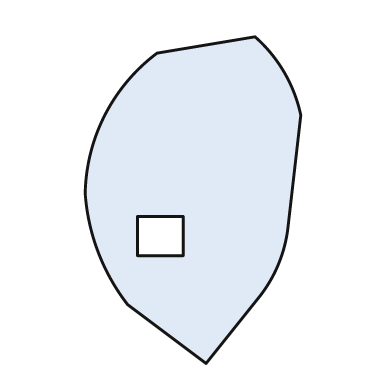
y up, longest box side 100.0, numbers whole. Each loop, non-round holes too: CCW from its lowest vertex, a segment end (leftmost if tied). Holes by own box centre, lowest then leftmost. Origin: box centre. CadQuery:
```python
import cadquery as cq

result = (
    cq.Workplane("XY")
    .moveTo(4.0, -50.0)
    .lineTo(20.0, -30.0)
    .threePointArc((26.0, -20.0), (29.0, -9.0))
    .lineTo(33.0, 26.0)
    .threePointArc((28.0, 39.0), (19.0, 50.0))
    .lineTo(-11.0, 45.0)
    .threePointArc((-27.0, 26.0), (-33.0, 2.0))
    .threePointArc((-29.0, -16.0), (-20.0, -32.0))
    .close()
    .moveTo(-17.0, -17.0)
    .lineTo(-3.0, -17.0)
    .lineTo(-3.0, -5.0)
    .lineTo(-17.0, -5.0)
    .close()
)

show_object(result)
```